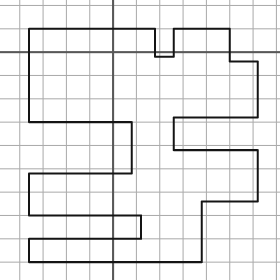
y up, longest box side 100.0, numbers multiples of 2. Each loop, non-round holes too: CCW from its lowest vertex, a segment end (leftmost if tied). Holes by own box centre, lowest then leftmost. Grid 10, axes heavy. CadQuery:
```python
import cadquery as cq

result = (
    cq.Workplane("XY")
    .moveTo(-36.0, -90.0)
    .lineTo(38.0, -90.0)
    .lineTo(38.0, -64.0)
    .lineTo(62.0, -64.0)
    .lineTo(62.0, -42.0)
    .lineTo(26.0, -42.0)
    .lineTo(26.0, -28.0)
    .lineTo(62.0, -28.0)
    .lineTo(62.0, -4.0)
    .lineTo(50.0, -4.0)
    .lineTo(50.0, 10.0)
    .lineTo(26.0, 10.0)
    .lineTo(26.0, -2.0)
    .lineTo(18.0, -2.0)
    .lineTo(18.0, 10.0)
    .lineTo(-36.0, 10.0)
    .lineTo(-36.0, -30.0)
    .lineTo(8.0, -30.0)
    .lineTo(8.0, -52.0)
    .lineTo(-36.0, -52.0)
    .lineTo(-36.0, -70.0)
    .lineTo(12.0, -70.0)
    .lineTo(12.0, -80.0)
    .lineTo(-36.0, -80.0)
    .close()
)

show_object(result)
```